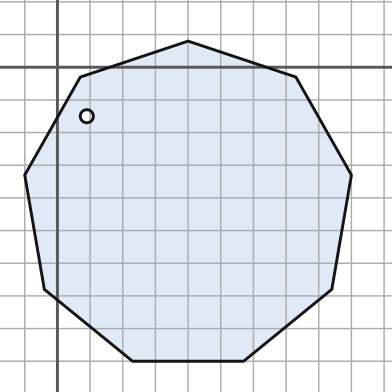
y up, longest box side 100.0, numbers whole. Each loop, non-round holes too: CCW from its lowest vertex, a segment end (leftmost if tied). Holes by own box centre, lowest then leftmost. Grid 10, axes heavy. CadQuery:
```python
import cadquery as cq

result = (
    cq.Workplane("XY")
    .moveTo(23.0, -90.0)
    .lineTo(57.0, -90.0)
    .lineTo(84.0, -68.0)
    .lineTo(90.0, -33.0)
    .lineTo(73.0, -3.0)
    .lineTo(40.0, 8.0)
    .lineTo(7.0, -3.0)
    .lineTo(-10.0, -33.0)
    .lineTo(-4.0, -68.0)
    .close()
    .moveTo(9.0, -15.0)
    .circle(2.0)
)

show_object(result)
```